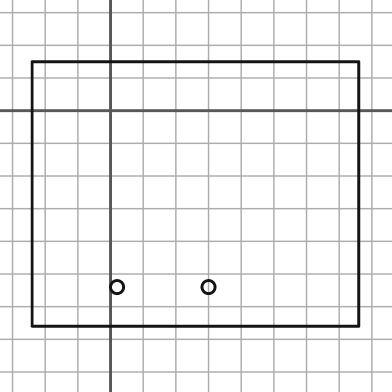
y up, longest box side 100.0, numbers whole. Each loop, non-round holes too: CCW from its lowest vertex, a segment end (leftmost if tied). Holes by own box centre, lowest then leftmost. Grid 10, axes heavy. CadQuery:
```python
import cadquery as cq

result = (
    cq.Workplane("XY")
    .moveTo(-24.0, -66.0)
    .lineTo(76.0, -66.0)
    .lineTo(76.0, 15.0)
    .lineTo(-24.0, 15.0)
    .close()
    .moveTo(2.0, -54.0)
    .circle(2.0)
    .moveTo(30.0, -54.0)
    .circle(2.0)
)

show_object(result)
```